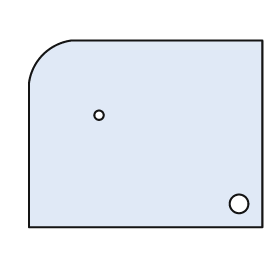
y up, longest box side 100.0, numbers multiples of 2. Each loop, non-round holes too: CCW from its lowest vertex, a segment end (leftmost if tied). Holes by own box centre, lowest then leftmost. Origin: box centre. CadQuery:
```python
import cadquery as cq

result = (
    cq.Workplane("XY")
    .moveTo(-50.0, -40.0)
    .lineTo(50.0, -40.0)
    .lineTo(50.0, 40.0)
    .lineTo(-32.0, 40.0)
    .threePointArc((-44.0, 34.0), (-50.0, 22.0))
    .close()
    .moveTo(40.0, -30.0)
    .circle(4.0)
    .moveTo(-20.0, 8.0)
    .circle(2.0)
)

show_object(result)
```